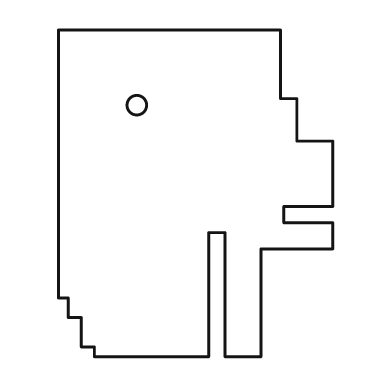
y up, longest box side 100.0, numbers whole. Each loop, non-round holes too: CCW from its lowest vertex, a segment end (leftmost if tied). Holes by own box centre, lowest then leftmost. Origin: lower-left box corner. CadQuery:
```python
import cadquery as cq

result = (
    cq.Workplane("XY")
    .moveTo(11.0, 0.0)
    .lineTo(46.0, 0.0)
    .lineTo(46.0, 38.0)
    .lineTo(51.0, 38.0)
    .lineTo(51.0, 0.0)
    .lineTo(62.0, 0.0)
    .lineTo(62.0, 33.0)
    .lineTo(84.0, 33.0)
    .lineTo(84.0, 41.0)
    .lineTo(69.0, 41.0)
    .lineTo(69.0, 46.0)
    .lineTo(84.0, 46.0)
    .lineTo(84.0, 66.0)
    .lineTo(73.0, 66.0)
    .lineTo(73.0, 79.0)
    .lineTo(68.0, 79.0)
    .lineTo(68.0, 100.0)
    .lineTo(0.0, 100.0)
    .lineTo(0.0, 18.0)
    .lineTo(3.0, 18.0)
    .lineTo(3.0, 12.0)
    .lineTo(7.0, 12.0)
    .lineTo(7.0, 3.0)
    .lineTo(11.0, 3.0)
    .close()
    .moveTo(24.0, 77.0)
    .circle(3.0)
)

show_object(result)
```